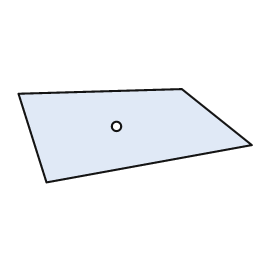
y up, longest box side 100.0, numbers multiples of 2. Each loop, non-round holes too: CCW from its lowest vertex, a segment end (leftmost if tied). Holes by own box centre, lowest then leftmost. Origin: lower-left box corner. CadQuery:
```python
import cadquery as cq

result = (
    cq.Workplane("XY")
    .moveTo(12.0, 0.0)
    .lineTo(100.0, 16.0)
    .lineTo(70.0, 40.0)
    .lineTo(0.0, 38.0)
    .close()
    .moveTo(42.0, 24.0)
    .circle(2.0)
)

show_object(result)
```